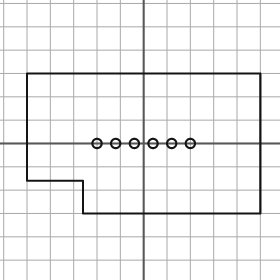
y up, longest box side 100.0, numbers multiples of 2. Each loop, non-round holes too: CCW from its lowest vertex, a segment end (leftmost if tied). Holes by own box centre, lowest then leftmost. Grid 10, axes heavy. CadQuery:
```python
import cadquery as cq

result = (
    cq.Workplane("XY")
    .moveTo(-26.0, -30.0)
    .lineTo(50.0, -30.0)
    .lineTo(50.0, 30.0)
    .lineTo(-50.0, 30.0)
    .lineTo(-50.0, -16.0)
    .lineTo(-26.0, -16.0)
    .close()
    .moveTo(-20.0, 0.0)
    .circle(2.0)
    .moveTo(-12.0, 0.0)
    .circle(2.0)
    .moveTo(-4.0, 0.0)
    .circle(2.0)
    .moveTo(4.0, 0.0)
    .circle(2.0)
    .moveTo(12.0, 0.0)
    .circle(2.0)
    .moveTo(20.0, 0.0)
    .circle(2.0)
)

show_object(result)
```